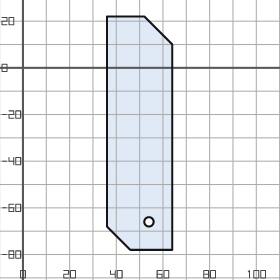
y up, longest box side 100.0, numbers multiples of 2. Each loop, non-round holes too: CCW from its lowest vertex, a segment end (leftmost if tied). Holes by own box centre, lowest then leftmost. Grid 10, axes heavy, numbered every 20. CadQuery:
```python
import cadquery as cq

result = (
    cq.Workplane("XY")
    .moveTo(46.0, -78.0)
    .lineTo(64.0, -78.0)
    .lineTo(64.0, 10.0)
    .lineTo(52.0, 22.0)
    .lineTo(36.0, 22.0)
    .lineTo(36.0, -68.0)
    .close()
    .moveTo(54.0, -66.0)
    .circle(2.0)
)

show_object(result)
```